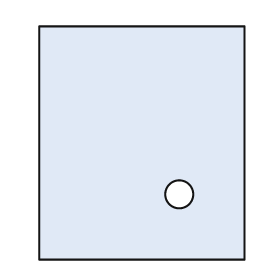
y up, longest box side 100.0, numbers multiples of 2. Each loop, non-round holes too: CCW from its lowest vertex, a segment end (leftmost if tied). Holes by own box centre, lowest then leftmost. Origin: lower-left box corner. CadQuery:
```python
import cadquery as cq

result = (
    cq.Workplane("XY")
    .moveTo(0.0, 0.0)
    .lineTo(88.0, 0.0)
    .lineTo(88.0, 100.0)
    .lineTo(0.0, 100.0)
    .close()
    .moveTo(60.0, 28.0)
    .circle(6.0)
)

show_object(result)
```